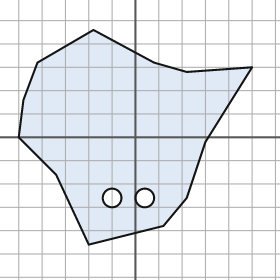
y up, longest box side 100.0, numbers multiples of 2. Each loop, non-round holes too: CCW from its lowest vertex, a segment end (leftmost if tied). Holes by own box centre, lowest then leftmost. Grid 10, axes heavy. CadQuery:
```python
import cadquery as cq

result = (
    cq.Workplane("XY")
    .moveTo(-20.0, -46.0)
    .lineTo(12.0, -38.0)
    .lineTo(22.0, -26.0)
    .lineTo(30.0, -2.0)
    .lineTo(50.0, 30.0)
    .lineTo(22.0, 28.0)
    .lineTo(8.0, 32.0)
    .lineTo(-18.0, 46.0)
    .lineTo(-42.0, 32.0)
    .lineTo(-48.0, 16.0)
    .lineTo(-50.0, 0.0)
    .lineTo(-34.0, -16.0)
    .close()
    .moveTo(-10.0, -26.0)
    .circle(4.0)
    .moveTo(4.0, -26.0)
    .circle(4.0)
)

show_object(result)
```